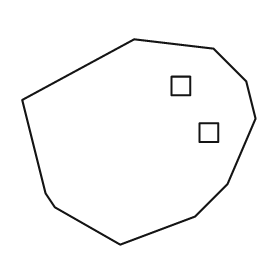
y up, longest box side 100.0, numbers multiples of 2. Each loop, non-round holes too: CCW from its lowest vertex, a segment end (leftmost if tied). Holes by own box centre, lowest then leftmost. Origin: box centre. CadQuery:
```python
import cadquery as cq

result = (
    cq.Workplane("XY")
    .moveTo(-8.0, -44.0)
    .lineTo(24.0, -32.0)
    .lineTo(38.0, -18.0)
    .lineTo(50.0, 10.0)
    .lineTo(46.0, 26.0)
    .lineTo(32.0, 40.0)
    .lineTo(-2.0, 44.0)
    .lineTo(-50.0, 18.0)
    .lineTo(-40.0, -22.0)
    .lineTo(-36.0, -28.0)
    .close()
    .moveTo(26.0, 0.0)
    .lineTo(34.0, 0.0)
    .lineTo(34.0, 8.0)
    .lineTo(26.0, 8.0)
    .close()
    .moveTo(14.0, 20.0)
    .lineTo(22.0, 20.0)
    .lineTo(22.0, 28.0)
    .lineTo(14.0, 28.0)
    .close()
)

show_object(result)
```